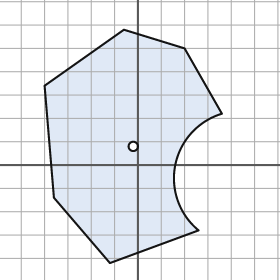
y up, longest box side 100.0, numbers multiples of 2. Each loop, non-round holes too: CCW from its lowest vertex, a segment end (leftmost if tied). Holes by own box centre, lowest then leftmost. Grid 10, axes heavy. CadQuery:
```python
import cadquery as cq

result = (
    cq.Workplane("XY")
    .moveTo(-12.0, -42.0)
    .lineTo(26.0, -28.0)
    .threePointArc((16.0, 0.0), (36.0, 22.0))
    .lineTo(20.0, 50.0)
    .lineTo(-6.0, 58.0)
    .lineTo(-40.0, 34.0)
    .lineTo(-36.0, -14.0)
    .close()
    .moveTo(-2.0, 8.0)
    .circle(2.0)
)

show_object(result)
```